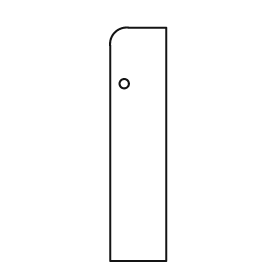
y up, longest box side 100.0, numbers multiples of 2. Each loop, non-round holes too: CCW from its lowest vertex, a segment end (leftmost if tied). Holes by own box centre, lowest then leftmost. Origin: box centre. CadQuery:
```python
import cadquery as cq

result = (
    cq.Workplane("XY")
    .moveTo(-12.0, -50.0)
    .lineTo(12.0, -50.0)
    .lineTo(12.0, 50.0)
    .lineTo(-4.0, 50.0)
    .threePointArc((-10.0, 48.0), (-12.0, 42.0))
    .close()
    .moveTo(-6.0, 26.0)
    .circle(2.0)
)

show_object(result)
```